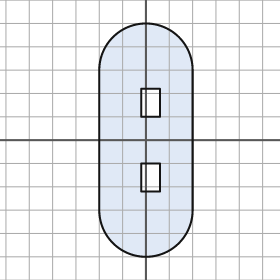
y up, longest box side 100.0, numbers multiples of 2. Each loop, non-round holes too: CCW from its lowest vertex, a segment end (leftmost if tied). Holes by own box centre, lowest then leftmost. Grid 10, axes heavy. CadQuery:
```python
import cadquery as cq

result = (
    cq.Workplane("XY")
    .moveTo(-20.0, -30.0)
    .threePointArc((0.0, -50.0), (20.0, -30.0))
    .lineTo(20.0, 30.0)
    .threePointArc((0.0, 50.0), (-20.0, 30.0))
    .close()
    .moveTo(-2.0, -22.0)
    .lineTo(6.0, -22.0)
    .lineTo(6.0, -10.0)
    .lineTo(-2.0, -10.0)
    .close()
    .moveTo(-2.0, 10.0)
    .lineTo(6.0, 10.0)
    .lineTo(6.0, 22.0)
    .lineTo(-2.0, 22.0)
    .close()
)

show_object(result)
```